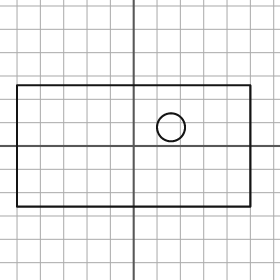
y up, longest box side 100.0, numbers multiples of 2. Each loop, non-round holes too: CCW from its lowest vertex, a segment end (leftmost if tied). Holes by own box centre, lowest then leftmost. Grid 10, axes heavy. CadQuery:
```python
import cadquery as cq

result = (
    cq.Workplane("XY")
    .moveTo(-50.0, -26.0)
    .lineTo(50.0, -26.0)
    .lineTo(50.0, 26.0)
    .lineTo(-50.0, 26.0)
    .close()
    .moveTo(16.0, 8.0)
    .circle(6.0)
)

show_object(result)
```